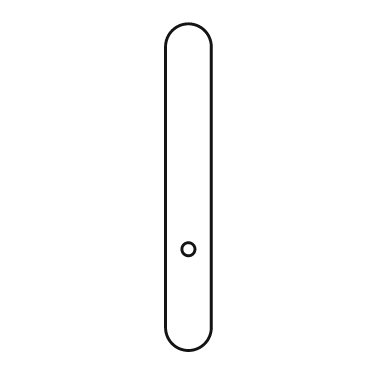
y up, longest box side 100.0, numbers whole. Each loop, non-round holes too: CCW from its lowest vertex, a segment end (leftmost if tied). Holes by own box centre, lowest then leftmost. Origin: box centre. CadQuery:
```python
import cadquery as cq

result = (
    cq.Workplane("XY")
    .moveTo(-7.0, -43.0)
    .threePointArc((0.0, -50.0), (7.0, -43.0))
    .lineTo(7.0, 43.0)
    .threePointArc((0.0, 50.0), (-7.0, 43.0))
    .close()
    .moveTo(0.0, -19.0)
    .circle(2.0)
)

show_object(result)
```